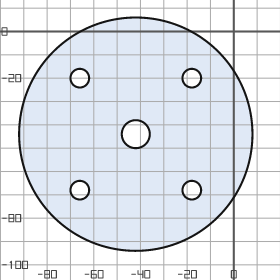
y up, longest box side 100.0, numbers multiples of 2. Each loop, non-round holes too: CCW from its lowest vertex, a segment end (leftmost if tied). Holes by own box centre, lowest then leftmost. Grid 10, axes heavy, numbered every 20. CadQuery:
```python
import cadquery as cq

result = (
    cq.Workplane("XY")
    .moveTo(-42.0, -44.0)
    .circle(50.0)
    .moveTo(-66.0, -68.0)
    .circle(4.0)
    .moveTo(-18.0, -68.0)
    .circle(4.0)
    .moveTo(-42.0, -44.0)
    .circle(6.0)
    .moveTo(-66.0, -20.0)
    .circle(4.0)
    .moveTo(-18.0, -20.0)
    .circle(4.0)
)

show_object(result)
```